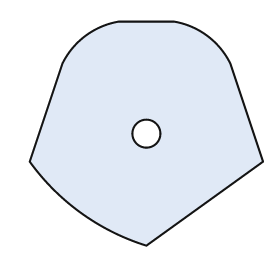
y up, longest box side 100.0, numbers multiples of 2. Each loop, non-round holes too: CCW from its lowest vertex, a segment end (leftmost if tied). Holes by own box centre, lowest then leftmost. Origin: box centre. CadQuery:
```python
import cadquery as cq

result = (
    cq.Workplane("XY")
    .moveTo(0.0, -48.0)
    .lineTo(50.0, -12.0)
    .lineTo(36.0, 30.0)
    .threePointArc((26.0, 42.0), (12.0, 48.0))
    .lineTo(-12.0, 48.0)
    .threePointArc((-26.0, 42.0), (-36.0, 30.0))
    .lineTo(-50.0, -12.0)
    .threePointArc((-28.0, -34.0), (0.0, -48.0))
    .close()
    .moveTo(0.0, 0.0)
    .circle(6.0)
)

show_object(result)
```